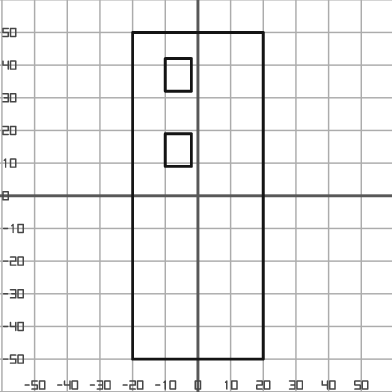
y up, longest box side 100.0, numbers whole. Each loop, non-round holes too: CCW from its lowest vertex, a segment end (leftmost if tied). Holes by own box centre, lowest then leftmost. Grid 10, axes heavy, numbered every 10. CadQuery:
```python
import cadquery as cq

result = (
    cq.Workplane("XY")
    .moveTo(-20.0, -50.0)
    .lineTo(20.0, -50.0)
    .lineTo(20.0, 50.0)
    .lineTo(-20.0, 50.0)
    .close()
    .moveTo(-10.0, 9.0)
    .lineTo(-2.0, 9.0)
    .lineTo(-2.0, 19.0)
    .lineTo(-10.0, 19.0)
    .close()
    .moveTo(-10.0, 32.0)
    .lineTo(-2.0, 32.0)
    .lineTo(-2.0, 42.0)
    .lineTo(-10.0, 42.0)
    .close()
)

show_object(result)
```